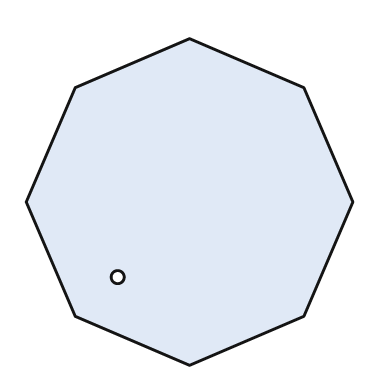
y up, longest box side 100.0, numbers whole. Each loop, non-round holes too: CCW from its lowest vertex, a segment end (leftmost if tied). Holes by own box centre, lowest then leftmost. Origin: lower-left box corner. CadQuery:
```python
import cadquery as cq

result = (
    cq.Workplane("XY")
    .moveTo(50.0, 0.0)
    .lineTo(85.0, 15.0)
    .lineTo(100.0, 50.0)
    .lineTo(85.0, 85.0)
    .lineTo(50.0, 100.0)
    .lineTo(15.0, 85.0)
    .lineTo(0.0, 50.0)
    .lineTo(15.0, 15.0)
    .close()
    .moveTo(28.0, 27.0)
    .circle(2.0)
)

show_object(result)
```